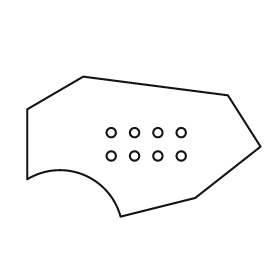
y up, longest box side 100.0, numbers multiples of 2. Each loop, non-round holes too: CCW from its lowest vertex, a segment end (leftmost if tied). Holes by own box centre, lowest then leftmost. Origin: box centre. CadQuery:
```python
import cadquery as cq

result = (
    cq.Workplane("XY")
    .moveTo(-10.0, -30.0)
    .lineTo(22.0, -22.0)
    .lineTo(50.0, 0.0)
    .lineTo(36.0, 22.0)
    .lineTo(-26.0, 30.0)
    .lineTo(-50.0, 16.0)
    .lineTo(-50.0, -14.0)
    .threePointArc((-26.0, -12.0), (-10.0, -30.0))
    .close()
    .moveTo(-14.0, -4.0)
    .circle(2.0)
    .moveTo(-4.0, -4.0)
    .circle(2.0)
    .moveTo(6.0, -4.0)
    .circle(2.0)
    .moveTo(16.0, -4.0)
    .circle(2.0)
    .moveTo(-14.0, 6.0)
    .circle(2.0)
    .moveTo(-4.0, 6.0)
    .circle(2.0)
    .moveTo(6.0, 6.0)
    .circle(2.0)
    .moveTo(16.0, 6.0)
    .circle(2.0)
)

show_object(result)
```